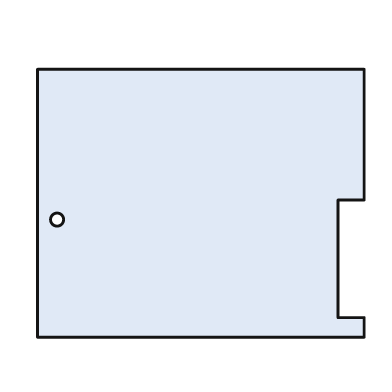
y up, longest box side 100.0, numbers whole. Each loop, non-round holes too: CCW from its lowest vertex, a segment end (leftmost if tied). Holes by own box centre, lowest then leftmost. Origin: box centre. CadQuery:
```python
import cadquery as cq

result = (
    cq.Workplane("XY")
    .moveTo(-50.0, -41.0)
    .lineTo(50.0, -41.0)
    .lineTo(50.0, -35.0)
    .lineTo(42.0, -35.0)
    .lineTo(42.0, 1.0)
    .lineTo(50.0, 1.0)
    .lineTo(50.0, 41.0)
    .lineTo(-50.0, 41.0)
    .close()
    .moveTo(-44.0, -5.0)
    .circle(2.0)
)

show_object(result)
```